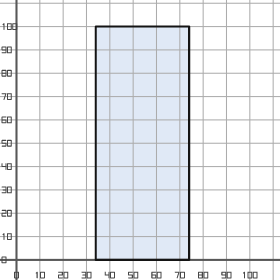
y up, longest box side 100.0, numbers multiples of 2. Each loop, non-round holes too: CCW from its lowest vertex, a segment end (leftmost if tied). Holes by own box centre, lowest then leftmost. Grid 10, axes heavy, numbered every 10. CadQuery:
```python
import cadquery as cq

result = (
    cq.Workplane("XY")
    .moveTo(34.0, 0.0)
    .lineTo(74.0, 0.0)
    .lineTo(74.0, 100.0)
    .lineTo(34.0, 100.0)
    .close()
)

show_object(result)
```